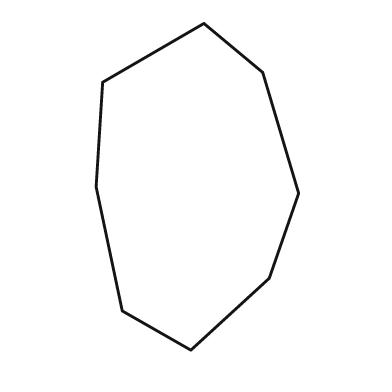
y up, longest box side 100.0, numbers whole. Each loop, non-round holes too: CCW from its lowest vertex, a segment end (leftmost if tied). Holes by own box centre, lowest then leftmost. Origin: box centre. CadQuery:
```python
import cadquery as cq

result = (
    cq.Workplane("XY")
    .moveTo(-2.0, -50.0)
    .lineTo(22.0, -28.0)
    .lineTo(31.0, -2.0)
    .lineTo(20.0, 35.0)
    .lineTo(2.0, 50.0)
    .lineTo(-29.0, 32.0)
    .lineTo(-31.0, 0.0)
    .lineTo(-23.0, -38.0)
    .close()
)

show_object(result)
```